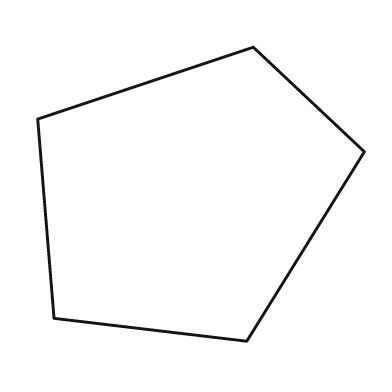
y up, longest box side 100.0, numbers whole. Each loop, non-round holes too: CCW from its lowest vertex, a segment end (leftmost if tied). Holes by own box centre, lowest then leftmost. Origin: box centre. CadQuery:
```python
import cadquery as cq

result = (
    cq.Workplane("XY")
    .moveTo(14.0, -45.0)
    .lineTo(50.0, 13.0)
    .lineTo(16.0, 45.0)
    .lineTo(-50.0, 23.0)
    .lineTo(-45.0, -38.0)
    .close()
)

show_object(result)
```